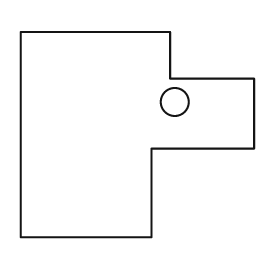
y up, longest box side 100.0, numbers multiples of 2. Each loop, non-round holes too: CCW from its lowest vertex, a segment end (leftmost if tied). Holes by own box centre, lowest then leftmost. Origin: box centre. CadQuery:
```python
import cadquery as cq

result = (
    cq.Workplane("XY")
    .moveTo(-50.0, -44.0)
    .lineTo(6.0, -44.0)
    .lineTo(6.0, -6.0)
    .lineTo(50.0, -6.0)
    .lineTo(50.0, 24.0)
    .lineTo(14.0, 24.0)
    .lineTo(14.0, 44.0)
    .lineTo(-50.0, 44.0)
    .close()
    .moveTo(16.0, 14.0)
    .circle(6.0)
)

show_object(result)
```